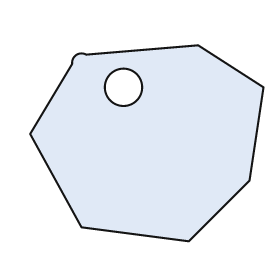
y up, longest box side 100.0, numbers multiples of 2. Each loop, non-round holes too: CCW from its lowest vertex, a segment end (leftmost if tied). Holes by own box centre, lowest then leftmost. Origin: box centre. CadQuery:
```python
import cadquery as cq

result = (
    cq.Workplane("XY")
    .moveTo(18.0, -42.0)
    .lineTo(44.0, -16.0)
    .lineTo(50.0, 24.0)
    .lineTo(22.0, 42.0)
    .lineTo(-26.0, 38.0)
    .threePointArc((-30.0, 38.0), (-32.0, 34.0))
    .lineTo(-50.0, 4.0)
    .lineTo(-28.0, -36.0)
    .close()
    .moveTo(-10.0, 24.0)
    .circle(8.0)
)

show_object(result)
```